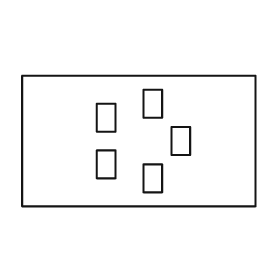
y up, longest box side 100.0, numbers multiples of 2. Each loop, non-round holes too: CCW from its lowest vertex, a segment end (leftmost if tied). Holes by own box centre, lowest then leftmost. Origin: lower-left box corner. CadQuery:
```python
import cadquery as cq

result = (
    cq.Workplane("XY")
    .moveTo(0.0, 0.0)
    .lineTo(100.0, 0.0)
    .lineTo(100.0, 56.0)
    .lineTo(0.0, 56.0)
    .close()
    .moveTo(52.0, 6.0)
    .lineTo(60.0, 6.0)
    .lineTo(60.0, 18.0)
    .lineTo(52.0, 18.0)
    .close()
    .moveTo(32.0, 12.0)
    .lineTo(40.0, 12.0)
    .lineTo(40.0, 24.0)
    .lineTo(32.0, 24.0)
    .close()
    .moveTo(64.0, 22.0)
    .lineTo(72.0, 22.0)
    .lineTo(72.0, 34.0)
    .lineTo(64.0, 34.0)
    .close()
    .moveTo(32.0, 32.0)
    .lineTo(40.0, 32.0)
    .lineTo(40.0, 44.0)
    .lineTo(32.0, 44.0)
    .close()
    .moveTo(52.0, 38.0)
    .lineTo(60.0, 38.0)
    .lineTo(60.0, 50.0)
    .lineTo(52.0, 50.0)
    .close()
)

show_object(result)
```